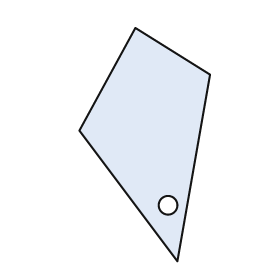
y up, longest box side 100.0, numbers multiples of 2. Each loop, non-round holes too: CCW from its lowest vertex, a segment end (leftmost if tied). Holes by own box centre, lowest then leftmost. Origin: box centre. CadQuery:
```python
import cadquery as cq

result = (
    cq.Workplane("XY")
    .moveTo(14.0, -50.0)
    .lineTo(28.0, 30.0)
    .lineTo(-4.0, 50.0)
    .lineTo(-28.0, 6.0)
    .close()
    .moveTo(10.0, -26.0)
    .circle(4.0)
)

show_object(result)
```